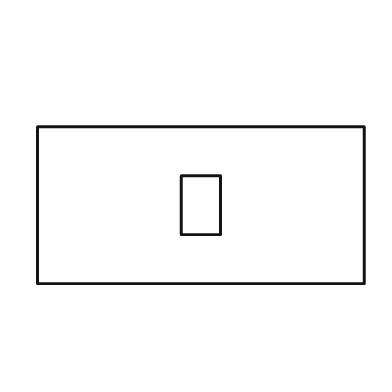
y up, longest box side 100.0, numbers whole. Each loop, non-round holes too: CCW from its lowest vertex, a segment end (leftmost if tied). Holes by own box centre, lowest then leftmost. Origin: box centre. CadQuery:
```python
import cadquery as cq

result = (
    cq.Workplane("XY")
    .moveTo(-50.0, -24.0)
    .lineTo(50.0, -24.0)
    .lineTo(50.0, 24.0)
    .lineTo(-50.0, 24.0)
    .close()
    .moveTo(-6.0, -9.0)
    .lineTo(6.0, -9.0)
    .lineTo(6.0, 9.0)
    .lineTo(-6.0, 9.0)
    .close()
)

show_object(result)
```